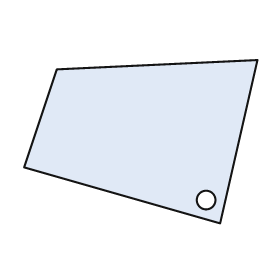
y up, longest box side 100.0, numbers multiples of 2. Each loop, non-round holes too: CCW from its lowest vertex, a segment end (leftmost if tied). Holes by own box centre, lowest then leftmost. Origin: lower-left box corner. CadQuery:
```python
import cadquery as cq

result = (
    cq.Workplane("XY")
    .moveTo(84.0, 0.0)
    .lineTo(100.0, 70.0)
    .lineTo(14.0, 66.0)
    .lineTo(0.0, 24.0)
    .close()
    .moveTo(78.0, 10.0)
    .circle(4.0)
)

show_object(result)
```